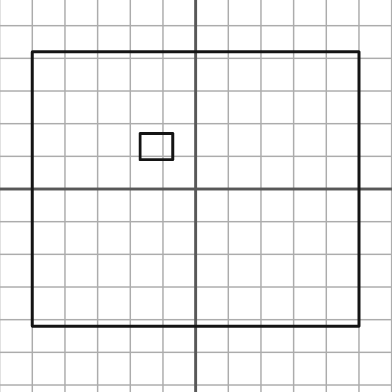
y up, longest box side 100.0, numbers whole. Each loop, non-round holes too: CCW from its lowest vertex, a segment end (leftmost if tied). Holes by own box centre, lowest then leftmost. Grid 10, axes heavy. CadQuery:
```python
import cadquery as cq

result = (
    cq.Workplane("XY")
    .moveTo(-50.0, -42.0)
    .lineTo(50.0, -42.0)
    .lineTo(50.0, 42.0)
    .lineTo(-50.0, 42.0)
    .close()
    .moveTo(-17.0, 9.0)
    .lineTo(-7.0, 9.0)
    .lineTo(-7.0, 17.0)
    .lineTo(-17.0, 17.0)
    .close()
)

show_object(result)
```